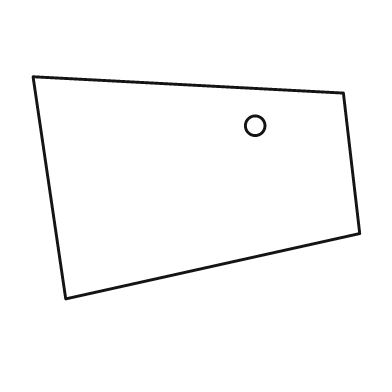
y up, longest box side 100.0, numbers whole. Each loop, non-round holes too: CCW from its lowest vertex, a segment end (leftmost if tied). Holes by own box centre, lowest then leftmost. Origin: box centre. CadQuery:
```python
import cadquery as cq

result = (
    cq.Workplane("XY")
    .moveTo(-40.0, -34.0)
    .lineTo(50.0, -14.0)
    .lineTo(45.0, 29.0)
    .lineTo(-50.0, 34.0)
    .close()
    .moveTo(18.0, 19.0)
    .circle(3.0)
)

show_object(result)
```